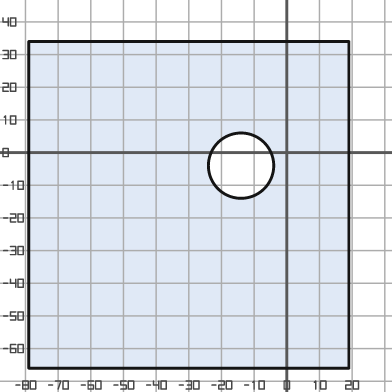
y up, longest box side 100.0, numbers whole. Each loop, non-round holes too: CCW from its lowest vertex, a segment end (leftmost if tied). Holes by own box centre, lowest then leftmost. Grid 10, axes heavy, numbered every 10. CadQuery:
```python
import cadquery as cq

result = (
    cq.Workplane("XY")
    .moveTo(-79.0, -66.0)
    .lineTo(19.0, -66.0)
    .lineTo(19.0, 34.0)
    .lineTo(-79.0, 34.0)
    .close()
    .moveTo(-14.0, -4.0)
    .circle(10.0)
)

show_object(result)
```